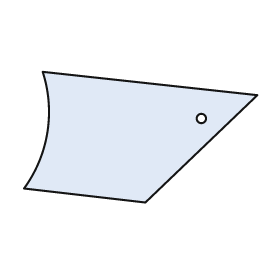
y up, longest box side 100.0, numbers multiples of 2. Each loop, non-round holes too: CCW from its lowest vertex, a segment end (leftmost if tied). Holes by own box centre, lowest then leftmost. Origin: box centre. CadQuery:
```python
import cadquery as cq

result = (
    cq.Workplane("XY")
    .moveTo(2.0, -28.0)
    .lineTo(50.0, 18.0)
    .lineTo(-42.0, 28.0)
    .threePointArc((-40.0, 2.0), (-50.0, -22.0))
    .close()
    .moveTo(26.0, 8.0)
    .circle(2.0)
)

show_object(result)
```